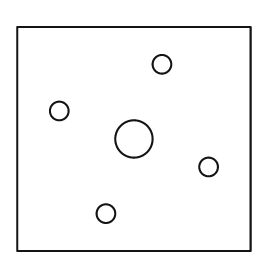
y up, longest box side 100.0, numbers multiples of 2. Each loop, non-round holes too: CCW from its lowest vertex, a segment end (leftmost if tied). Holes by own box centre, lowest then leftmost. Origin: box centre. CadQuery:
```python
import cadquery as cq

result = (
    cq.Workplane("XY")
    .moveTo(-50.0, -48.0)
    .lineTo(50.0, -48.0)
    .lineTo(50.0, 48.0)
    .lineTo(-50.0, 48.0)
    .close()
    .moveTo(-12.0, -32.0)
    .circle(4.0)
    .moveTo(32.0, -12.0)
    .circle(4.0)
    .moveTo(0.0, 0.0)
    .circle(8.0)
    .moveTo(-32.0, 12.0)
    .circle(4.0)
    .moveTo(12.0, 32.0)
    .circle(4.0)
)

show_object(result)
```